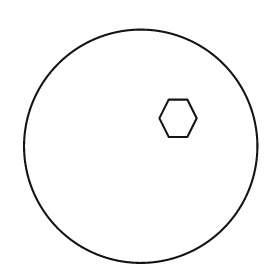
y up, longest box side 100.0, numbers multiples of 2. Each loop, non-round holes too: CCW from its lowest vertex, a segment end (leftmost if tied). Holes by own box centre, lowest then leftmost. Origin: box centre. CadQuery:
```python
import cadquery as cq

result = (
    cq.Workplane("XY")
    .moveTo(0.0, 0.0)
    .circle(50.0)
    .moveTo(12.0, 4.0)
    .lineTo(20.0, 4.0)
    .lineTo(24.0, 12.0)
    .lineTo(20.0, 20.0)
    .lineTo(12.0, 20.0)
    .lineTo(8.0, 12.0)
    .close()
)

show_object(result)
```